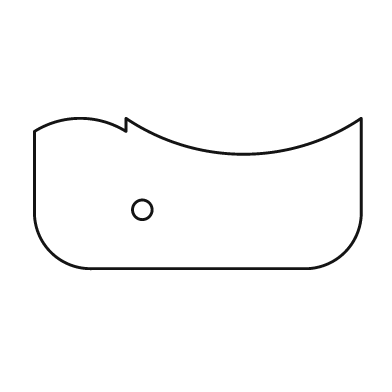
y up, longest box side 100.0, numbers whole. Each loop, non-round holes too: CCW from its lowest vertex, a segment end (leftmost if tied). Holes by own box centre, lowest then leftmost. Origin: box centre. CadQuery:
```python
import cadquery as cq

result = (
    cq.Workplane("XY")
    .moveTo(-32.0, -23.0)
    .lineTo(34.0, -23.0)
    .threePointArc((45.0, -18.0), (50.0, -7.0))
    .lineTo(50.0, 23.0)
    .threePointArc((14.0, 12.0), (-22.0, 23.0))
    .lineTo(-22.0, 19.0)
    .threePointArc((-36.0, 23.0), (-50.0, 19.0))
    .lineTo(-50.0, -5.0)
    .threePointArc((-45.0, -18.0), (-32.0, -23.0))
    .close()
    .moveTo(-17.0, -5.0)
    .circle(3.0)
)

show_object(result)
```